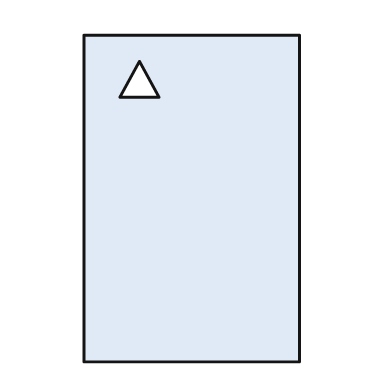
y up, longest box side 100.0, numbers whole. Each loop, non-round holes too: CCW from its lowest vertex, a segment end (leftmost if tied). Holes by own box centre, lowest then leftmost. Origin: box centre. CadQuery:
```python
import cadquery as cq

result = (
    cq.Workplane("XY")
    .moveTo(-33.0, -50.0)
    .lineTo(33.0, -50.0)
    .lineTo(33.0, 50.0)
    .lineTo(-33.0, 50.0)
    .close()
    .moveTo(-22.0, 31.0)
    .lineTo(-10.0, 31.0)
    .lineTo(-16.0, 42.0)
    .close()
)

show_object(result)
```